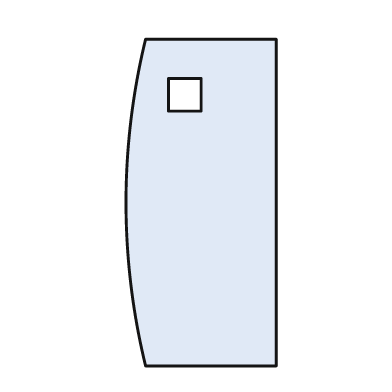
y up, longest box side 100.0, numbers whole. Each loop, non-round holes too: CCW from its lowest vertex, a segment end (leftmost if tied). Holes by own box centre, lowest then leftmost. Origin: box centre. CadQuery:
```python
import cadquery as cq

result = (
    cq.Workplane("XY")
    .moveTo(-17.0, -50.0)
    .lineTo(23.0, -50.0)
    .lineTo(23.0, 50.0)
    .lineTo(-17.0, 50.0)
    .threePointArc((-23.0, 0.0), (-17.0, -50.0))
    .close()
    .moveTo(-10.0, 28.0)
    .lineTo(0.0, 28.0)
    .lineTo(0.0, 38.0)
    .lineTo(-10.0, 38.0)
    .close()
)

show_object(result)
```